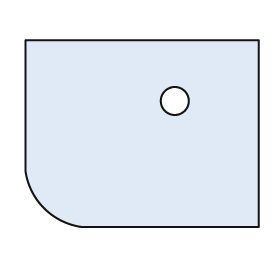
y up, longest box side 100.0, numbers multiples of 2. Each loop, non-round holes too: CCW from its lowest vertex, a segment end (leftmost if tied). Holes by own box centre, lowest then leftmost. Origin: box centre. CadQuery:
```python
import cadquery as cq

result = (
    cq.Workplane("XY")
    .moveTo(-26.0, -40.0)
    .lineTo(50.0, -40.0)
    .lineTo(50.0, 40.0)
    .lineTo(-50.0, 40.0)
    .lineTo(-50.0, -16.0)
    .threePointArc((-42.0, -32.0), (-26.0, -40.0))
    .close()
    .moveTo(14.0, 14.0)
    .circle(6.0)
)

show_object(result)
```